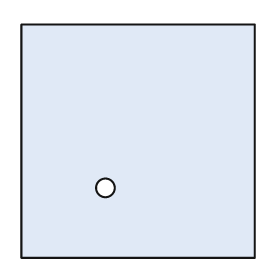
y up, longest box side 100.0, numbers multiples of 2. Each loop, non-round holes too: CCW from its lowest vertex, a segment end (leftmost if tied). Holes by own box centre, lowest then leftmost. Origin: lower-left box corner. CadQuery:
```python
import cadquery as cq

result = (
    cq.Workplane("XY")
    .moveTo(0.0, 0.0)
    .lineTo(100.0, 0.0)
    .lineTo(100.0, 100.0)
    .lineTo(0.0, 100.0)
    .close()
    .moveTo(36.0, 30.0)
    .circle(4.0)
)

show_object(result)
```